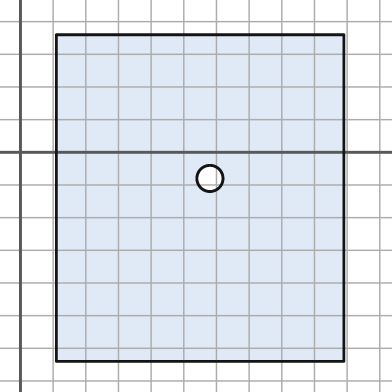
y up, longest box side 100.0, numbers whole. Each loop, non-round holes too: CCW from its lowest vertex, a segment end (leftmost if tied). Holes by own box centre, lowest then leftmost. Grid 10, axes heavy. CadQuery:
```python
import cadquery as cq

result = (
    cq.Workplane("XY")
    .moveTo(11.0, -64.0)
    .lineTo(99.0, -64.0)
    .lineTo(99.0, 36.0)
    .lineTo(11.0, 36.0)
    .close()
    .moveTo(58.0, -8.0)
    .circle(4.0)
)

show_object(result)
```